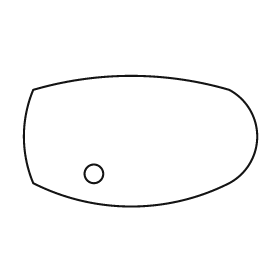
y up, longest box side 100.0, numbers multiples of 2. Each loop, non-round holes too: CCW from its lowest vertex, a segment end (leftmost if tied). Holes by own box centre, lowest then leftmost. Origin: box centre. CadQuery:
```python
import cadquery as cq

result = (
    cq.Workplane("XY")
    .moveTo(-46.0, -18.0)
    .threePointArc((-4.0, -28.0), (38.0, -18.0))
    .threePointArc((50.0, 2.0), (38.0, 22.0))
    .threePointArc((-4.0, 28.0), (-46.0, 22.0))
    .threePointArc((-50.0, 2.0), (-46.0, -18.0))
    .close()
    .moveTo(-20.0, -14.0)
    .circle(4.0)
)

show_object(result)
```